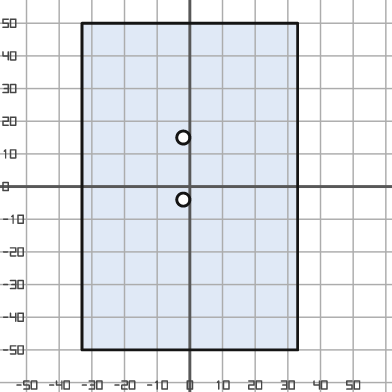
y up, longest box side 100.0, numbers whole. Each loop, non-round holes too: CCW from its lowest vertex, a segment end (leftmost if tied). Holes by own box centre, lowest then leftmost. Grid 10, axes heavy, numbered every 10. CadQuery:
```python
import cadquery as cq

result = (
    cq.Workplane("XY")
    .moveTo(-33.0, -50.0)
    .lineTo(33.0, -50.0)
    .lineTo(33.0, 50.0)
    .lineTo(-33.0, 50.0)
    .close()
    .moveTo(-2.0, -4.0)
    .circle(2.0)
    .moveTo(-2.0, 15.0)
    .circle(2.0)
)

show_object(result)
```